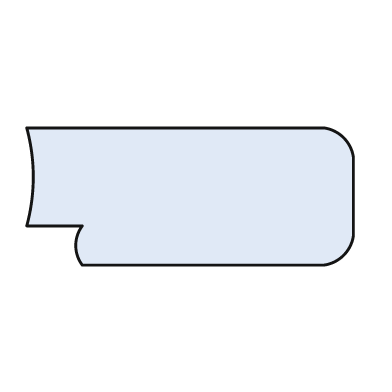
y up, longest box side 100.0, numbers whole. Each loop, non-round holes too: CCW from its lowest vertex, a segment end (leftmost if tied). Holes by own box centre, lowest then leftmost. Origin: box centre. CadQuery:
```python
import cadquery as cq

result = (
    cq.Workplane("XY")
    .moveTo(-33.0, -21.0)
    .lineTo(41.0, -21.0)
    .threePointArc((47.0, -18.0), (50.0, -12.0))
    .lineTo(50.0, 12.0)
    .threePointArc((47.0, 18.0), (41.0, 21.0))
    .lineTo(-50.0, 21.0)
    .threePointArc((-48.0, 6.0), (-50.0, -9.0))
    .lineTo(-33.0, -9.0)
    .threePointArc((-35.0, -15.0), (-33.0, -21.0))
    .close()
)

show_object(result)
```